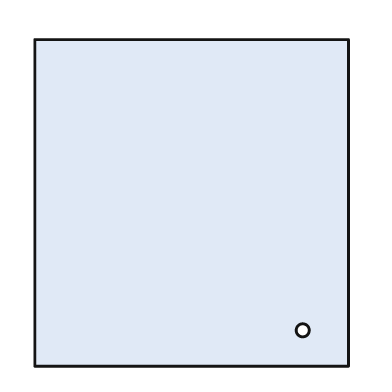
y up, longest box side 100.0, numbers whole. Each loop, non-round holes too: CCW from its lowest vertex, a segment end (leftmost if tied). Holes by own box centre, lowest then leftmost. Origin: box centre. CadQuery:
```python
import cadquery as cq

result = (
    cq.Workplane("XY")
    .moveTo(-48.0, -50.0)
    .lineTo(48.0, -50.0)
    .lineTo(48.0, 50.0)
    .lineTo(-48.0, 50.0)
    .close()
    .moveTo(34.0, -39.0)
    .circle(2.0)
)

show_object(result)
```